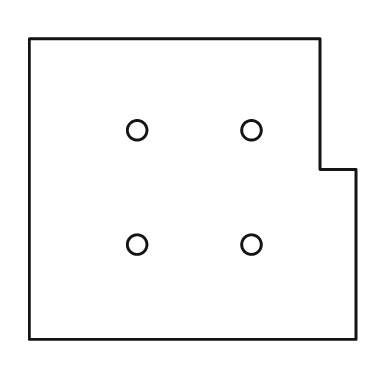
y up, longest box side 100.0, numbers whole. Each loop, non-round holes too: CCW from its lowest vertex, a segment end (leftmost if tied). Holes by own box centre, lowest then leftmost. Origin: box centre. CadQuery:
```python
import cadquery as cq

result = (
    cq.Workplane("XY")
    .moveTo(-50.0, -46.0)
    .lineTo(50.0, -46.0)
    .lineTo(50.0, 6.0)
    .lineTo(39.0, 6.0)
    .lineTo(39.0, 46.0)
    .lineTo(-50.0, 46.0)
    .close()
    .moveTo(-17.0, -17.0)
    .circle(3.0)
    .moveTo(18.0, -17.0)
    .circle(3.0)
    .moveTo(-17.0, 18.0)
    .circle(3.0)
    .moveTo(18.0, 18.0)
    .circle(3.0)
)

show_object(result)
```